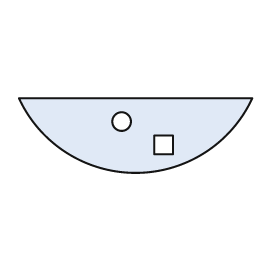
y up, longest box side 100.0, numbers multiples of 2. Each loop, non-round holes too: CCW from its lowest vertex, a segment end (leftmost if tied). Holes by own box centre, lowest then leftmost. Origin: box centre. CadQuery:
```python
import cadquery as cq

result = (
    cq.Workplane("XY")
    .moveTo(-50.0, 16.0)
    .threePointArc((0.0, -16.0), (50.0, 16.0))
    .close()
    .moveTo(8.0, -8.0)
    .lineTo(16.0, -8.0)
    .lineTo(16.0, 0.0)
    .lineTo(8.0, 0.0)
    .close()
    .moveTo(-6.0, 6.0)
    .circle(4.0)
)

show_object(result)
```